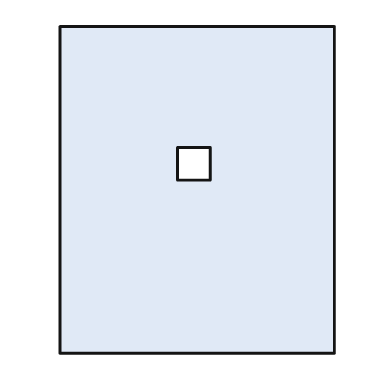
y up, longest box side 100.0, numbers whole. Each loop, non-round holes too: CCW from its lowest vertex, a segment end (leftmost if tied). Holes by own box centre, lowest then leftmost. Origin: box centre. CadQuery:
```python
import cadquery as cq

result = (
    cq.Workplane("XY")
    .moveTo(-42.0, -50.0)
    .lineTo(42.0, -50.0)
    .lineTo(42.0, 50.0)
    .lineTo(-42.0, 50.0)
    .close()
    .moveTo(-6.0, 3.0)
    .lineTo(4.0, 3.0)
    .lineTo(4.0, 13.0)
    .lineTo(-6.0, 13.0)
    .close()
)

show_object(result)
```